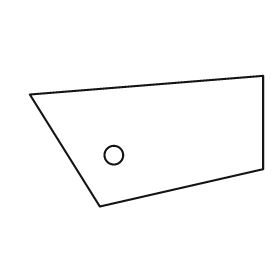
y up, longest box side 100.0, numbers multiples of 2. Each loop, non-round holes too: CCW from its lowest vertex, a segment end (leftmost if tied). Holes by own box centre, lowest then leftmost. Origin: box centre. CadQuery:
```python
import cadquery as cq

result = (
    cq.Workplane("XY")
    .moveTo(-20.0, -28.0)
    .lineTo(50.0, -12.0)
    .lineTo(50.0, 28.0)
    .lineTo(-50.0, 20.0)
    .close()
    .moveTo(-14.0, -6.0)
    .circle(4.0)
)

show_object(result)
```